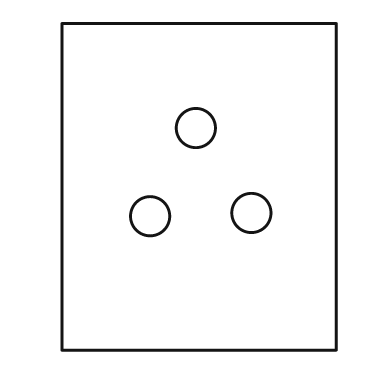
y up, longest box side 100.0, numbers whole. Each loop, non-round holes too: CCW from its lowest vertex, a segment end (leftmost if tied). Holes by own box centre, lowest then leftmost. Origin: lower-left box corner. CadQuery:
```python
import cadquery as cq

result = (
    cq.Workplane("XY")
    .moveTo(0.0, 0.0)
    .lineTo(84.0, 0.0)
    .lineTo(84.0, 100.0)
    .lineTo(0.0, 100.0)
    .close()
    .moveTo(27.0, 41.0)
    .circle(6.0)
    .moveTo(58.0, 42.0)
    .circle(6.0)
    .moveTo(41.0, 68.0)
    .circle(6.0)
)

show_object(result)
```